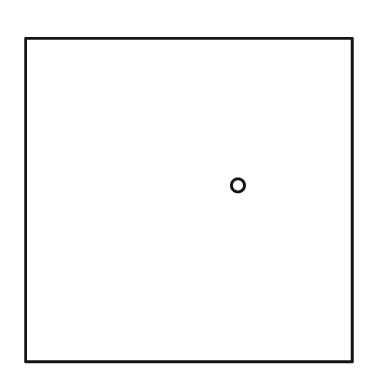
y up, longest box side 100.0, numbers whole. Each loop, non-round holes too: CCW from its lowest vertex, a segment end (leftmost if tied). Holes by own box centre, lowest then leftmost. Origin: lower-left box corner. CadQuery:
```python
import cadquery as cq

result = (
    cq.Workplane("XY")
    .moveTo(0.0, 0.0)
    .lineTo(100.0, 0.0)
    .lineTo(100.0, 99.0)
    .lineTo(0.0, 99.0)
    .close()
    .moveTo(65.0, 54.0)
    .circle(2.0)
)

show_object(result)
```